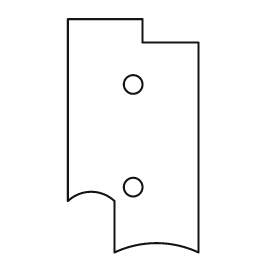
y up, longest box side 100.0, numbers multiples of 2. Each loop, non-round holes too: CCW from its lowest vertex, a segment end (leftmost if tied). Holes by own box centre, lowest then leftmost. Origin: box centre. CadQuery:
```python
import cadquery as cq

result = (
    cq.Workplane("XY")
    .moveTo(-8.0, -50.0)
    .threePointArc((10.0, -46.0), (28.0, -50.0))
    .lineTo(28.0, 40.0)
    .lineTo(4.0, 40.0)
    .lineTo(4.0, 50.0)
    .lineTo(-28.0, 50.0)
    .lineTo(-28.0, -28.0)
    .threePointArc((-18.0, -24.0), (-8.0, -28.0))
    .close()
    .moveTo(0.0, -22.0)
    .circle(4.0)
    .moveTo(0.0, 22.0)
    .circle(4.0)
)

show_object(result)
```